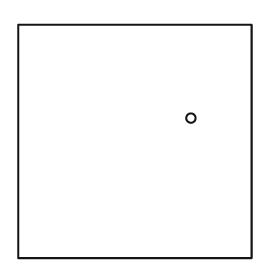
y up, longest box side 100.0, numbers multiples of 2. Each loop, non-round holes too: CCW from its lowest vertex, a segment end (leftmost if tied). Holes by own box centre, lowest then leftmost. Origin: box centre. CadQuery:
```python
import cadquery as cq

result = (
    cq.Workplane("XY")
    .moveTo(-50.0, -50.0)
    .lineTo(50.0, -50.0)
    .lineTo(50.0, 50.0)
    .lineTo(-50.0, 50.0)
    .close()
    .moveTo(24.0, 10.0)
    .circle(2.0)
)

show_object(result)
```